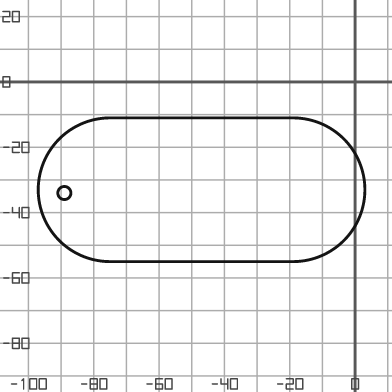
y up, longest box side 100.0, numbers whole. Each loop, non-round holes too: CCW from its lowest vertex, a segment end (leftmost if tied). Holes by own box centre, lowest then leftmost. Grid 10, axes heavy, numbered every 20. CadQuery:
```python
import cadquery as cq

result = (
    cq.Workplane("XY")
    .moveTo(-75.0, -55.0)
    .lineTo(-19.0, -55.0)
    .threePointArc((3.0, -33.0), (-19.0, -11.0))
    .lineTo(-75.0, -11.0)
    .threePointArc((-97.0, -33.0), (-75.0, -55.0))
    .close()
    .moveTo(-89.0, -34.0)
    .circle(2.0)
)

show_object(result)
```